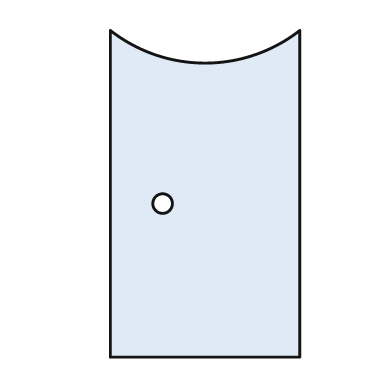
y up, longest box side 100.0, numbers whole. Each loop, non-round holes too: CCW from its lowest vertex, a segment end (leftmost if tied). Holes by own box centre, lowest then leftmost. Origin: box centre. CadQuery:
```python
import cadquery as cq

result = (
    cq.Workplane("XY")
    .moveTo(-29.0, -50.0)
    .lineTo(29.0, -50.0)
    .lineTo(29.0, 50.0)
    .threePointArc((0.0, 40.0), (-29.0, 50.0))
    .close()
    .moveTo(-13.0, -3.0)
    .circle(3.0)
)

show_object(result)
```